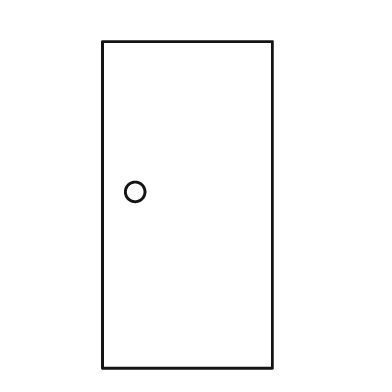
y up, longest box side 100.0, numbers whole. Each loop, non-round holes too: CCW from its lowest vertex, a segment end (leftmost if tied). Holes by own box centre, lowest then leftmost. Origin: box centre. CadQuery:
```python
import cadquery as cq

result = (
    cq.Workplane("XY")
    .moveTo(-26.0, -50.0)
    .lineTo(26.0, -50.0)
    .lineTo(26.0, 50.0)
    .lineTo(-26.0, 50.0)
    .close()
    .moveTo(-16.0, 4.0)
    .circle(3.0)
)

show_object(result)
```